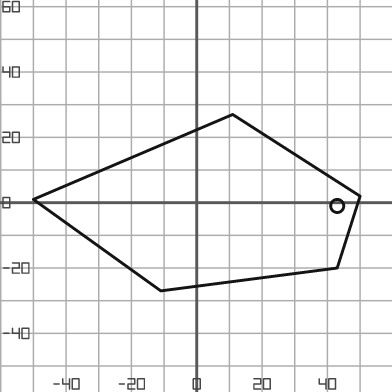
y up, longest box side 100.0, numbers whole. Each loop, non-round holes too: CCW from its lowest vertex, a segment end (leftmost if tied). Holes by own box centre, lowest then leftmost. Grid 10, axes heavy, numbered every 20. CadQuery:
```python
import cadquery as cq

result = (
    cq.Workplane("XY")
    .moveTo(-11.0, -27.0)
    .lineTo(43.0, -20.0)
    .lineTo(50.0, 2.0)
    .lineTo(11.0, 27.0)
    .lineTo(-50.0, 1.0)
    .close()
    .moveTo(43.0, -1.0)
    .circle(2.0)
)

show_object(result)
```